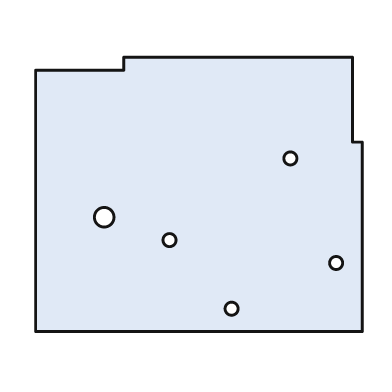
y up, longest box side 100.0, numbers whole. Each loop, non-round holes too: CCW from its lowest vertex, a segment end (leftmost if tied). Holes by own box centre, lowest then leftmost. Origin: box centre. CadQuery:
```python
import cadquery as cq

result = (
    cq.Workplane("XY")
    .moveTo(-50.0, -42.0)
    .lineTo(50.0, -42.0)
    .lineTo(50.0, 16.0)
    .lineTo(47.0, 16.0)
    .lineTo(47.0, 42.0)
    .lineTo(-23.0, 42.0)
    .lineTo(-23.0, 38.0)
    .lineTo(-50.0, 38.0)
    .close()
    .moveTo(10.0, -35.0)
    .circle(2.0)
    .moveTo(42.0, -21.0)
    .circle(2.0)
    .moveTo(-9.0, -14.0)
    .circle(2.0)
    .moveTo(-29.0, -7.0)
    .circle(3.0)
    .moveTo(28.0, 11.0)
    .circle(2.0)
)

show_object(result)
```